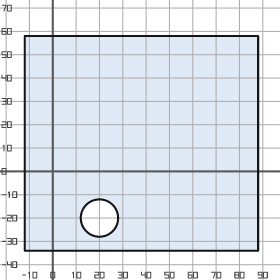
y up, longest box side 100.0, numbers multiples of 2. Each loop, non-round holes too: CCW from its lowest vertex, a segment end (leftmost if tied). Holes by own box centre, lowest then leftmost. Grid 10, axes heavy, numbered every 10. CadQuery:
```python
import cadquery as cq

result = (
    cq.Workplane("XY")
    .moveTo(-12.0, -34.0)
    .lineTo(88.0, -34.0)
    .lineTo(88.0, 58.0)
    .lineTo(-12.0, 58.0)
    .close()
    .moveTo(20.0, -20.0)
    .circle(8.0)
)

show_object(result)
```